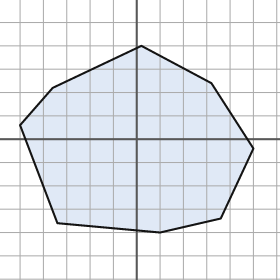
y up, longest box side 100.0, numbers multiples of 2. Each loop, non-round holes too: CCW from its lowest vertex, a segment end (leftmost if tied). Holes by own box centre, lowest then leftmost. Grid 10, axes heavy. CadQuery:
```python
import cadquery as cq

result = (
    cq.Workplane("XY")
    .moveTo(10.0, -40.0)
    .lineTo(36.0, -34.0)
    .lineTo(50.0, -4.0)
    .lineTo(32.0, 24.0)
    .lineTo(2.0, 40.0)
    .lineTo(-36.0, 22.0)
    .lineTo(-50.0, 6.0)
    .lineTo(-34.0, -36.0)
    .close()
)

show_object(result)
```